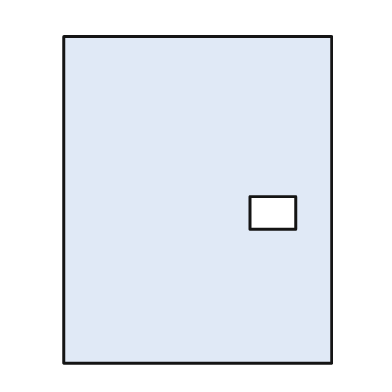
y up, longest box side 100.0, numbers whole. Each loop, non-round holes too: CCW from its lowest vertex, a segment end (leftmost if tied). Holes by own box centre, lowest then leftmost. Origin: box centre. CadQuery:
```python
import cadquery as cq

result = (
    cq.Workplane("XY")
    .moveTo(-41.0, -50.0)
    .lineTo(41.0, -50.0)
    .lineTo(41.0, 50.0)
    .lineTo(-41.0, 50.0)
    .close()
    .moveTo(16.0, -9.0)
    .lineTo(30.0, -9.0)
    .lineTo(30.0, 1.0)
    .lineTo(16.0, 1.0)
    .close()
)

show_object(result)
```